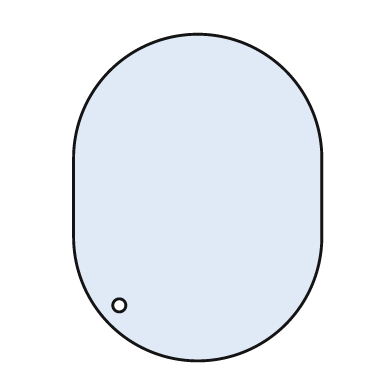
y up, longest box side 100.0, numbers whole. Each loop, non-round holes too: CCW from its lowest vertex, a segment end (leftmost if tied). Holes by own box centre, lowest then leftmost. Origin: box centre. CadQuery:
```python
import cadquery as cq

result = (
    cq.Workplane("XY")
    .moveTo(-38.0, -12.0)
    .threePointArc((0.0, -50.0), (38.0, -12.0))
    .lineTo(38.0, 12.0)
    .threePointArc((0.0, 50.0), (-38.0, 12.0))
    .close()
    .moveTo(-24.0, -33.0)
    .circle(2.0)
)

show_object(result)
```